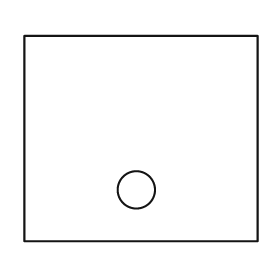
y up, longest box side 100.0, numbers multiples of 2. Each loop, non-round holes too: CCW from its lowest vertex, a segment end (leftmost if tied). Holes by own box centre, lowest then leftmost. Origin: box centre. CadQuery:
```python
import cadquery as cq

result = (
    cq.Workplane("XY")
    .moveTo(-50.0, -44.0)
    .lineTo(50.0, -44.0)
    .lineTo(50.0, 44.0)
    .lineTo(-50.0, 44.0)
    .close()
    .moveTo(-2.0, -22.0)
    .circle(8.0)
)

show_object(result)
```